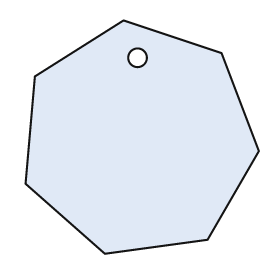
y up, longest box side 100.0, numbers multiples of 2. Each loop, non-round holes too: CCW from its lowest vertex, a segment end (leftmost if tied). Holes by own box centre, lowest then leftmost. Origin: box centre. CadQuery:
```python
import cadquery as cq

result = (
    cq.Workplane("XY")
    .moveTo(-16.0, -50.0)
    .lineTo(28.0, -44.0)
    .lineTo(50.0, -6.0)
    .lineTo(34.0, 36.0)
    .lineTo(-8.0, 50.0)
    .lineTo(-46.0, 26.0)
    .lineTo(-50.0, -20.0)
    .close()
    .moveTo(-2.0, 34.0)
    .circle(4.0)
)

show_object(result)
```